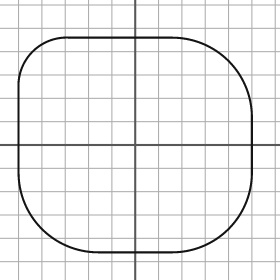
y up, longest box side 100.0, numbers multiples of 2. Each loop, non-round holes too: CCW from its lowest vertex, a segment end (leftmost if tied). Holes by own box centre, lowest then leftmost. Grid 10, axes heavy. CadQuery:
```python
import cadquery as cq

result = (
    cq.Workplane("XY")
    .moveTo(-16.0, -46.0)
    .lineTo(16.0, -46.0)
    .threePointArc((40.0, -36.0), (50.0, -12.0))
    .lineTo(50.0, 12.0)
    .threePointArc((40.0, 36.0), (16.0, 46.0))
    .lineTo(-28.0, 46.0)
    .threePointArc((-44.0, 40.0), (-50.0, 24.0))
    .lineTo(-50.0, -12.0)
    .threePointArc((-40.0, -36.0), (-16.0, -46.0))
    .close()
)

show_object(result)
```